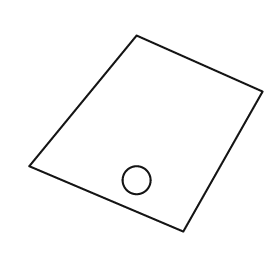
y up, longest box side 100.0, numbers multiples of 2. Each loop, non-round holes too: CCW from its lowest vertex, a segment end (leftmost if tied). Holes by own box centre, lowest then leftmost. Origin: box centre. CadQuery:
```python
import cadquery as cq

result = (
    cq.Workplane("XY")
    .moveTo(16.0, -42.0)
    .lineTo(50.0, 18.0)
    .lineTo(-4.0, 42.0)
    .lineTo(-50.0, -14.0)
    .close()
    .moveTo(-4.0, -20.0)
    .circle(6.0)
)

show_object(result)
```